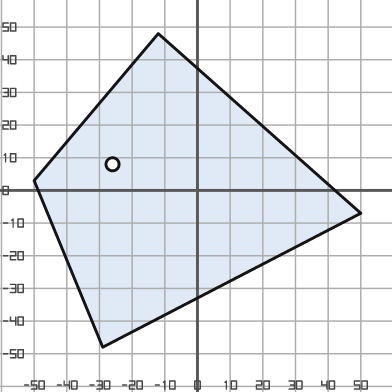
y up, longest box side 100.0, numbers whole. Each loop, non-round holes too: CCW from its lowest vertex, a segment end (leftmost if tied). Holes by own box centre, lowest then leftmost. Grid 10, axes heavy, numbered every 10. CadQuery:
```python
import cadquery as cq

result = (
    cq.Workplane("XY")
    .moveTo(-29.0, -48.0)
    .lineTo(50.0, -7.0)
    .lineTo(-12.0, 48.0)
    .lineTo(-50.0, 3.0)
    .close()
    .moveTo(-26.0, 8.0)
    .circle(2.0)
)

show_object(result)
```